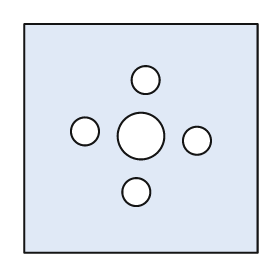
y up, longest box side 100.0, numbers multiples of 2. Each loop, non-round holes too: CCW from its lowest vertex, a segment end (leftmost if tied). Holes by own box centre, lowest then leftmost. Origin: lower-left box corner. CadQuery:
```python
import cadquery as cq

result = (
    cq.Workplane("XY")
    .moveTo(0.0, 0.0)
    .lineTo(100.0, 0.0)
    .lineTo(100.0, 98.0)
    .lineTo(0.0, 98.0)
    .close()
    .moveTo(48.0, 26.0)
    .circle(6.0)
    .moveTo(74.0, 48.0)
    .circle(6.0)
    .moveTo(50.0, 50.0)
    .circle(10.0)
    .moveTo(26.0, 52.0)
    .circle(6.0)
    .moveTo(52.0, 74.0)
    .circle(6.0)
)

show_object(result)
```